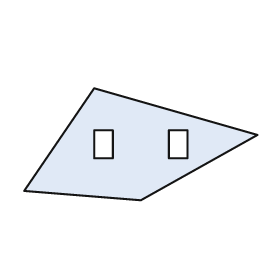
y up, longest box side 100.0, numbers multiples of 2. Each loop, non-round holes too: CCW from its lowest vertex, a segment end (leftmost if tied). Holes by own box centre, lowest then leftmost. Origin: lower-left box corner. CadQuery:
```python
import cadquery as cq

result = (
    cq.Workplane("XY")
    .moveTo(50.0, 0.0)
    .lineTo(100.0, 28.0)
    .lineTo(30.0, 48.0)
    .lineTo(0.0, 4.0)
    .close()
    .moveTo(30.0, 18.0)
    .lineTo(38.0, 18.0)
    .lineTo(38.0, 30.0)
    .lineTo(30.0, 30.0)
    .close()
    .moveTo(62.0, 18.0)
    .lineTo(70.0, 18.0)
    .lineTo(70.0, 30.0)
    .lineTo(62.0, 30.0)
    .close()
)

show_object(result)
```